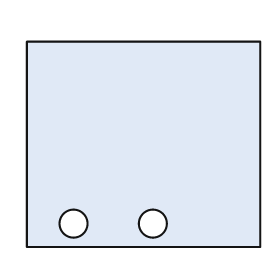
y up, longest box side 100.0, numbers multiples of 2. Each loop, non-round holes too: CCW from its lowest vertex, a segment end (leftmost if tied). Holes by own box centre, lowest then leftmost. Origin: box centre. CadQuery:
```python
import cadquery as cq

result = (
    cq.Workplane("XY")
    .moveTo(-50.0, -44.0)
    .lineTo(50.0, -44.0)
    .lineTo(50.0, 44.0)
    .lineTo(-50.0, 44.0)
    .close()
    .moveTo(-30.0, -34.0)
    .circle(6.0)
    .moveTo(4.0, -34.0)
    .circle(6.0)
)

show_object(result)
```